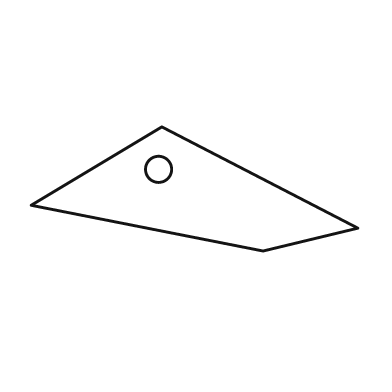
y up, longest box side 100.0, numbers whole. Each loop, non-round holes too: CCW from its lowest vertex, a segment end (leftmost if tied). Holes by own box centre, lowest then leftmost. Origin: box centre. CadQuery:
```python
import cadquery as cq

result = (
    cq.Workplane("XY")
    .moveTo(21.0, -19.0)
    .lineTo(50.0, -12.0)
    .lineTo(-10.0, 19.0)
    .lineTo(-50.0, -5.0)
    .close()
    .moveTo(-11.0, 6.0)
    .circle(4.0)
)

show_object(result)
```